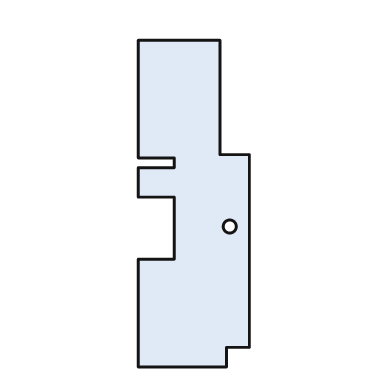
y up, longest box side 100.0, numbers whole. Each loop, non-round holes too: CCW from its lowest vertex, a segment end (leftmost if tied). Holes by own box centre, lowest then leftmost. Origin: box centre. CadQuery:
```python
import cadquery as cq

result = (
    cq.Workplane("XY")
    .moveTo(-17.0, -50.0)
    .lineTo(10.0, -50.0)
    .lineTo(10.0, -44.0)
    .lineTo(17.0, -44.0)
    .lineTo(17.0, 15.0)
    .lineTo(8.0, 15.0)
    .lineTo(8.0, 50.0)
    .lineTo(-17.0, 50.0)
    .lineTo(-17.0, 14.0)
    .lineTo(-6.0, 14.0)
    .lineTo(-6.0, 11.0)
    .lineTo(-17.0, 11.0)
    .lineTo(-17.0, 2.0)
    .lineTo(-6.0, 2.0)
    .lineTo(-6.0, -17.0)
    .lineTo(-17.0, -17.0)
    .close()
    .moveTo(11.0, -7.0)
    .circle(2.0)
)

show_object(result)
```